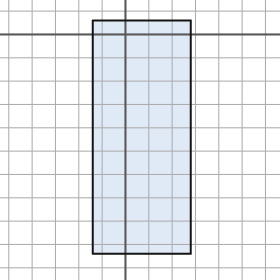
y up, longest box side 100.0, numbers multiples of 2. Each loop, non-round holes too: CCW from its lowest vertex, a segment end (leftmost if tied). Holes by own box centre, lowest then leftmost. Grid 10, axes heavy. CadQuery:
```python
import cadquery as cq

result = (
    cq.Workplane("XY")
    .moveTo(-14.0, -94.0)
    .lineTo(28.0, -94.0)
    .lineTo(28.0, 6.0)
    .lineTo(-14.0, 6.0)
    .close()
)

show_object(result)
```